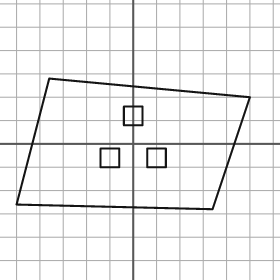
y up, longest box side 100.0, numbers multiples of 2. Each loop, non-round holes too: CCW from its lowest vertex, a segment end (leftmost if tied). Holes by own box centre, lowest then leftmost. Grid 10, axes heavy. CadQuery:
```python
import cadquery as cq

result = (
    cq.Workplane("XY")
    .moveTo(34.0, -28.0)
    .lineTo(50.0, 20.0)
    .lineTo(-36.0, 28.0)
    .lineTo(-50.0, -26.0)
    .close()
    .moveTo(-14.0, -10.0)
    .lineTo(-6.0, -10.0)
    .lineTo(-6.0, -2.0)
    .lineTo(-14.0, -2.0)
    .close()
    .moveTo(6.0, -10.0)
    .lineTo(14.0, -10.0)
    .lineTo(14.0, -2.0)
    .lineTo(6.0, -2.0)
    .close()
    .moveTo(-4.0, 8.0)
    .lineTo(4.0, 8.0)
    .lineTo(4.0, 16.0)
    .lineTo(-4.0, 16.0)
    .close()
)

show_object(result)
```